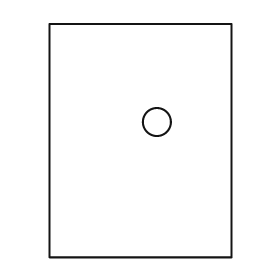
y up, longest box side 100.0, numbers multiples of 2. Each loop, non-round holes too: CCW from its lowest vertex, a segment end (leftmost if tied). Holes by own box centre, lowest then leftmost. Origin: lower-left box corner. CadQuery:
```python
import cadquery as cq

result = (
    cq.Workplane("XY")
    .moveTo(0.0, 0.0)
    .lineTo(78.0, 0.0)
    .lineTo(78.0, 100.0)
    .lineTo(0.0, 100.0)
    .close()
    .moveTo(46.0, 58.0)
    .circle(6.0)
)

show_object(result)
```